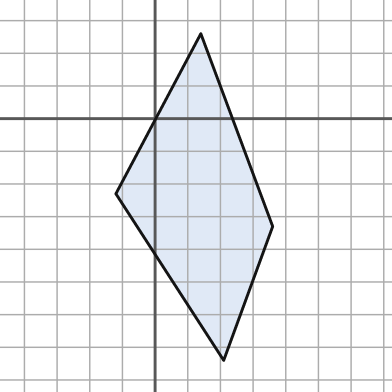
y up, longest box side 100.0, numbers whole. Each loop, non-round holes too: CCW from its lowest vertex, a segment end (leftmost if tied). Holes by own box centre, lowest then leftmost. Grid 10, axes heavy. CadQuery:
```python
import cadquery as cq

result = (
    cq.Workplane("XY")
    .moveTo(21.0, -74.0)
    .lineTo(36.0, -33.0)
    .lineTo(14.0, 26.0)
    .lineTo(-12.0, -23.0)
    .close()
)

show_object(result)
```